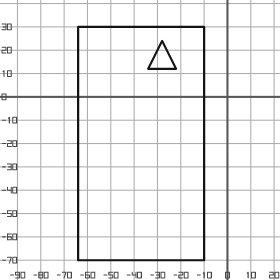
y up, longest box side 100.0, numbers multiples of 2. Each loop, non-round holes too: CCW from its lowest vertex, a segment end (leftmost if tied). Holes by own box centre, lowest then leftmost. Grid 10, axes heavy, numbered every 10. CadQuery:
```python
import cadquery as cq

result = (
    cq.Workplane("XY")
    .moveTo(-64.0, -70.0)
    .lineTo(-10.0, -70.0)
    .lineTo(-10.0, 30.0)
    .lineTo(-64.0, 30.0)
    .close()
    .moveTo(-34.0, 12.0)
    .lineTo(-22.0, 12.0)
    .lineTo(-28.0, 24.0)
    .close()
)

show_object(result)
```